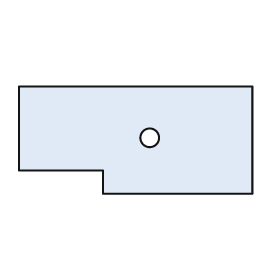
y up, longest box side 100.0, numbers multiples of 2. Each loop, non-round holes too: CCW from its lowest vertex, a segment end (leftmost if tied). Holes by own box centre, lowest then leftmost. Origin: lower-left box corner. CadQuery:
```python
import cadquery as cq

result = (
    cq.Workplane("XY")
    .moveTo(36.0, 0.0)
    .lineTo(100.0, 0.0)
    .lineTo(100.0, 46.0)
    .lineTo(0.0, 46.0)
    .lineTo(0.0, 10.0)
    .lineTo(36.0, 10.0)
    .close()
    .moveTo(56.0, 24.0)
    .circle(4.0)
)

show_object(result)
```